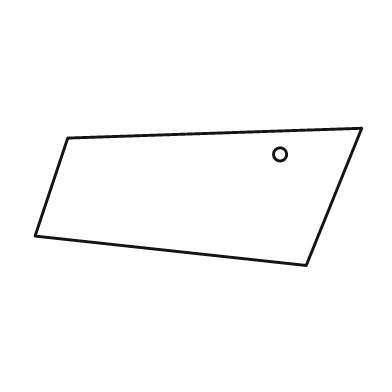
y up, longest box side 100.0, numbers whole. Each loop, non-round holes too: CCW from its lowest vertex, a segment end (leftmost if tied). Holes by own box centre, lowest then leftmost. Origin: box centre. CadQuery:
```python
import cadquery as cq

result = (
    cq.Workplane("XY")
    .moveTo(33.0, -21.0)
    .lineTo(50.0, 21.0)
    .lineTo(-40.0, 18.0)
    .lineTo(-50.0, -12.0)
    .close()
    .moveTo(25.0, 13.0)
    .circle(2.0)
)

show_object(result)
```